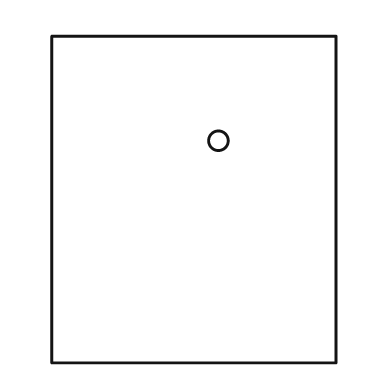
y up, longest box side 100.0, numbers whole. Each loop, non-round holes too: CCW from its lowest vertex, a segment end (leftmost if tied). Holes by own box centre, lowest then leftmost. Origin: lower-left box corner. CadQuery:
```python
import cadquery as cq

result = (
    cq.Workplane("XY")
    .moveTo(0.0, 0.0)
    .lineTo(87.0, 0.0)
    .lineTo(87.0, 100.0)
    .lineTo(0.0, 100.0)
    .close()
    .moveTo(51.0, 68.0)
    .circle(3.0)
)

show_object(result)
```